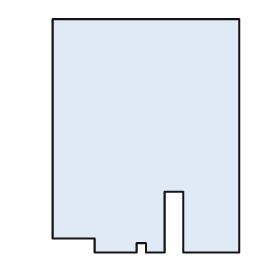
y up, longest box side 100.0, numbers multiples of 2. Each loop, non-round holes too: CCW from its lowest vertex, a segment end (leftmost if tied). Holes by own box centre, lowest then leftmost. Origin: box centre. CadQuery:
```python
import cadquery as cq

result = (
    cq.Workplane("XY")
    .moveTo(-22.0, -50.0)
    .lineTo(-4.0, -50.0)
    .lineTo(-4.0, -46.0)
    .lineTo(0.0, -46.0)
    .lineTo(0.0, -50.0)
    .lineTo(8.0, -50.0)
    .lineTo(8.0, -24.0)
    .lineTo(16.0, -24.0)
    .lineTo(16.0, -50.0)
    .lineTo(40.0, -50.0)
    .lineTo(40.0, 50.0)
    .lineTo(-40.0, 50.0)
    .lineTo(-40.0, -44.0)
    .lineTo(-22.0, -44.0)
    .close()
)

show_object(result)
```